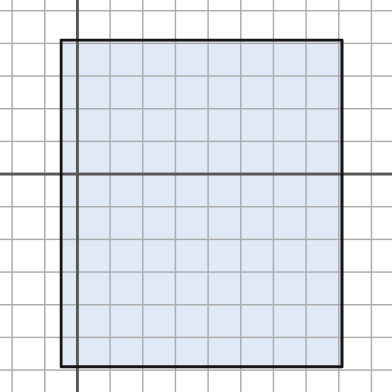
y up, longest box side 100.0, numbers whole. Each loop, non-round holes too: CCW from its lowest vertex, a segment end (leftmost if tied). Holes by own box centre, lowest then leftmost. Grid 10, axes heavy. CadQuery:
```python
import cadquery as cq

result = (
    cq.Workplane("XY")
    .moveTo(-5.0, -59.0)
    .lineTo(81.0, -59.0)
    .lineTo(81.0, 41.0)
    .lineTo(-5.0, 41.0)
    .close()
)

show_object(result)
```